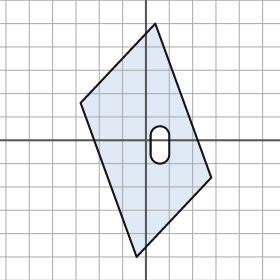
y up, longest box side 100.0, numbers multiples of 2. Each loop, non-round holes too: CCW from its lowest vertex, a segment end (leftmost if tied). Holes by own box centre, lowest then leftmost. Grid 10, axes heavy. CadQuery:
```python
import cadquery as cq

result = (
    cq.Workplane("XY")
    .moveTo(-4.0, -50.0)
    .lineTo(28.0, -16.0)
    .lineTo(4.0, 50.0)
    .lineTo(-28.0, 16.0)
    .close()
    .moveTo(2.0, -6.0)
    .threePointArc((6.0, -10.0), (10.0, -6.0))
    .lineTo(10.0, 2.0)
    .threePointArc((6.0, 6.0), (2.0, 2.0))
    .close()
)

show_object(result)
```